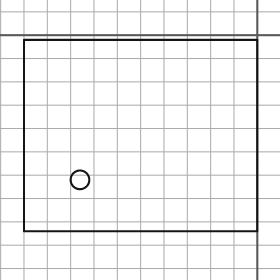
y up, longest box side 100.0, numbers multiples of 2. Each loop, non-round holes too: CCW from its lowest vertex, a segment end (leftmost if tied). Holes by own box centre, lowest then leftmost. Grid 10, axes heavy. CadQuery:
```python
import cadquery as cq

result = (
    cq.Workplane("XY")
    .moveTo(-100.0, -84.0)
    .lineTo(0.0, -84.0)
    .lineTo(0.0, -2.0)
    .lineTo(-100.0, -2.0)
    .close()
    .moveTo(-76.0, -62.0)
    .circle(4.0)
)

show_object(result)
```